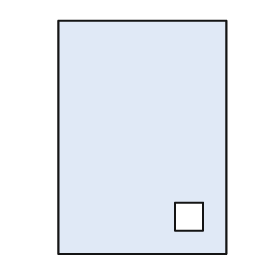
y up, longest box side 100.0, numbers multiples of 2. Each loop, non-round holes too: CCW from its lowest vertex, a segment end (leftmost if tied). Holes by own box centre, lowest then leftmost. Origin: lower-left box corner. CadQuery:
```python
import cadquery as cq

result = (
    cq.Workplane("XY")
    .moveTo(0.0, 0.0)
    .lineTo(72.0, 0.0)
    .lineTo(72.0, 100.0)
    .lineTo(0.0, 100.0)
    .close()
    .moveTo(50.0, 10.0)
    .lineTo(62.0, 10.0)
    .lineTo(62.0, 22.0)
    .lineTo(50.0, 22.0)
    .close()
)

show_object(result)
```